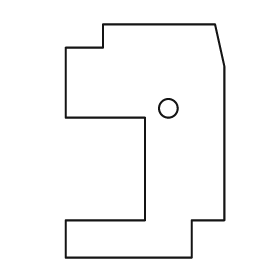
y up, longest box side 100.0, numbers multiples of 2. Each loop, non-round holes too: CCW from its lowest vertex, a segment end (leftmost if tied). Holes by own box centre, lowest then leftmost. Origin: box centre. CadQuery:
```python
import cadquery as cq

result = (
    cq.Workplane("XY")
    .moveTo(-34.0, -50.0)
    .lineTo(20.0, -50.0)
    .lineTo(20.0, -34.0)
    .lineTo(34.0, -34.0)
    .lineTo(34.0, 32.0)
    .lineTo(30.0, 50.0)
    .lineTo(-18.0, 50.0)
    .lineTo(-18.0, 40.0)
    .lineTo(-34.0, 40.0)
    .lineTo(-34.0, 10.0)
    .lineTo(0.0, 10.0)
    .lineTo(0.0, -34.0)
    .lineTo(-34.0, -34.0)
    .close()
    .moveTo(10.0, 14.0)
    .circle(4.0)
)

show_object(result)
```